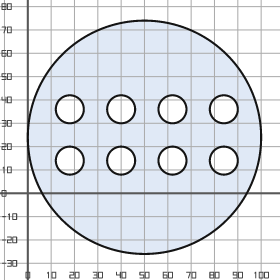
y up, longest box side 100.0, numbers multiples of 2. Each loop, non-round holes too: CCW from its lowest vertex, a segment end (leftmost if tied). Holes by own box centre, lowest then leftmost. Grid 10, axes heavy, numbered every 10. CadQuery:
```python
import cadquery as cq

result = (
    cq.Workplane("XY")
    .moveTo(50.0, 24.0)
    .circle(50.0)
    .moveTo(18.0, 14.0)
    .circle(6.0)
    .moveTo(40.0, 14.0)
    .circle(6.0)
    .moveTo(62.0, 14.0)
    .circle(6.0)
    .moveTo(84.0, 14.0)
    .circle(6.0)
    .moveTo(18.0, 36.0)
    .circle(6.0)
    .moveTo(40.0, 36.0)
    .circle(6.0)
    .moveTo(62.0, 36.0)
    .circle(6.0)
    .moveTo(84.0, 36.0)
    .circle(6.0)
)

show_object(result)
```